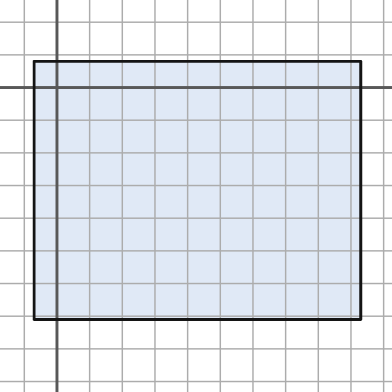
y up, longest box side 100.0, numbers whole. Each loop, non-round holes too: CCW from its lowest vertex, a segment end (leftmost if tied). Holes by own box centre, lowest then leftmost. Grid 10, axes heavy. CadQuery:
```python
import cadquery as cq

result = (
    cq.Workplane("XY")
    .moveTo(-7.0, -71.0)
    .lineTo(93.0, -71.0)
    .lineTo(93.0, 8.0)
    .lineTo(-7.0, 8.0)
    .close()
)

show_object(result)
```